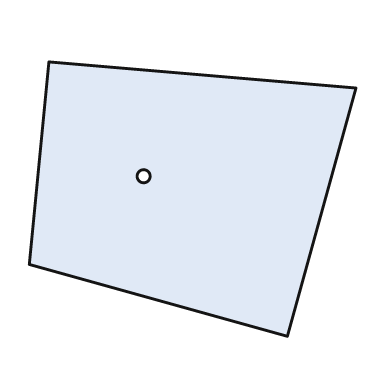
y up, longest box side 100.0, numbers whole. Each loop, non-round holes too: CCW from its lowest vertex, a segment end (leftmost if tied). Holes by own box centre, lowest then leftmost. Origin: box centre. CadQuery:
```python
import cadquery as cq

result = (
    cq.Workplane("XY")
    .moveTo(29.0, -42.0)
    .lineTo(50.0, 34.0)
    .lineTo(-44.0, 42.0)
    .lineTo(-50.0, -20.0)
    .close()
    .moveTo(-15.0, 7.0)
    .circle(2.0)
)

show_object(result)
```